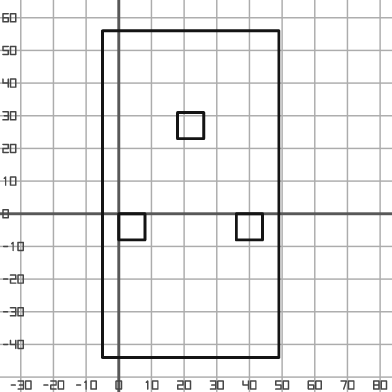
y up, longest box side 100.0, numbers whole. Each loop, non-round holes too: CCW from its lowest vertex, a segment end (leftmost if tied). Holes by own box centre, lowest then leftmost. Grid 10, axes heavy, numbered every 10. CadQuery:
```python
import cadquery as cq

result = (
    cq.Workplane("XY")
    .moveTo(-5.0, -44.0)
    .lineTo(49.0, -44.0)
    .lineTo(49.0, 56.0)
    .lineTo(-5.0, 56.0)
    .close()
    .moveTo(0.0, -8.0)
    .lineTo(8.0, -8.0)
    .lineTo(8.0, 0.0)
    .lineTo(0.0, 0.0)
    .close()
    .moveTo(36.0, -8.0)
    .lineTo(44.0, -8.0)
    .lineTo(44.0, 0.0)
    .lineTo(36.0, 0.0)
    .close()
    .moveTo(18.0, 23.0)
    .lineTo(26.0, 23.0)
    .lineTo(26.0, 31.0)
    .lineTo(18.0, 31.0)
    .close()
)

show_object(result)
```